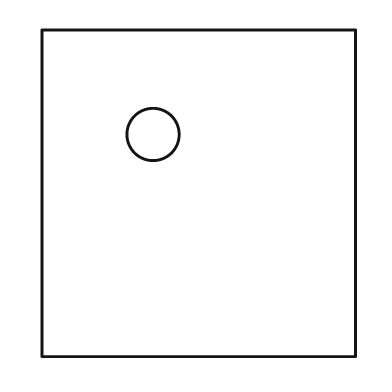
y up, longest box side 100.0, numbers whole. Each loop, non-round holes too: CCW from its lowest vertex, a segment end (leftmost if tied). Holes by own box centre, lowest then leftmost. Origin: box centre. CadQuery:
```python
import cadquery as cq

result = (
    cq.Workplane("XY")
    .moveTo(-48.0, -50.0)
    .lineTo(48.0, -50.0)
    .lineTo(48.0, 50.0)
    .lineTo(-48.0, 50.0)
    .close()
    .moveTo(-14.0, 18.0)
    .circle(8.0)
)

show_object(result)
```